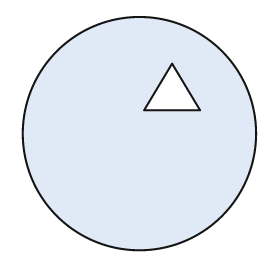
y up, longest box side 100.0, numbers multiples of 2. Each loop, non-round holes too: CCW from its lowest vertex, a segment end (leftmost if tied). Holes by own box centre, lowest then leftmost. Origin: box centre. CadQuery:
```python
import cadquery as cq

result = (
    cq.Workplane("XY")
    .moveTo(0.0, 0.0)
    .circle(50.0)
    .moveTo(2.0, 10.0)
    .lineTo(26.0, 10.0)
    .lineTo(14.0, 30.0)
    .close()
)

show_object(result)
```